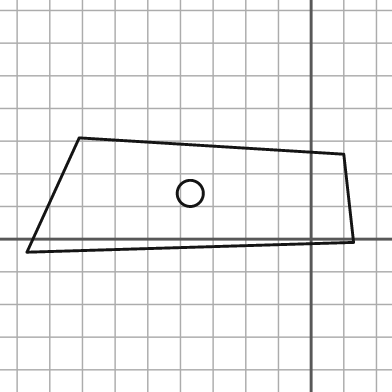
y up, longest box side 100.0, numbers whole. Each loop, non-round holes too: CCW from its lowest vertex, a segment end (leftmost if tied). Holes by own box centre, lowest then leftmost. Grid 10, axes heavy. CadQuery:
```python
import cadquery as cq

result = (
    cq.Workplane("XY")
    .moveTo(-87.0, -4.0)
    .lineTo(13.0, -1.0)
    .lineTo(10.0, 26.0)
    .lineTo(-71.0, 31.0)
    .close()
    .moveTo(-37.0, 14.0)
    .circle(4.0)
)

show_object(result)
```